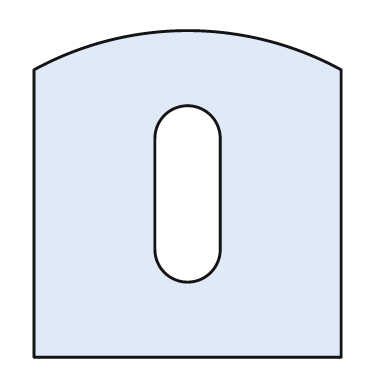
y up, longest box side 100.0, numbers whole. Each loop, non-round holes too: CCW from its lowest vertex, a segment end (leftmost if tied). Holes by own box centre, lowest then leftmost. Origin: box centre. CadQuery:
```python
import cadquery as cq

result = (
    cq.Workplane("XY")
    .moveTo(-47.0, -50.0)
    .lineTo(47.0, -50.0)
    .lineTo(47.0, 38.0)
    .threePointArc((0.0, 50.0), (-47.0, 38.0))
    .close()
    .moveTo(-10.0, -17.0)
    .threePointArc((0.0, -27.0), (10.0, -17.0))
    .lineTo(10.0, 17.0)
    .threePointArc((0.0, 27.0), (-10.0, 17.0))
    .close()
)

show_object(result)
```